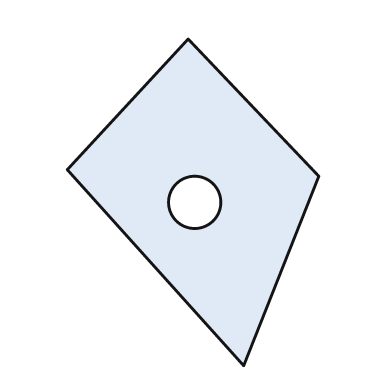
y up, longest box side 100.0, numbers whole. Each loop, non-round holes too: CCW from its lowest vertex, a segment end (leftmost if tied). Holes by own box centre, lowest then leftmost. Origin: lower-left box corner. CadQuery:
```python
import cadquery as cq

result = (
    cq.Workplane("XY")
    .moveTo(54.0, 0.0)
    .lineTo(77.0, 58.0)
    .lineTo(37.0, 100.0)
    .lineTo(0.0, 60.0)
    .close()
    .moveTo(39.0, 50.0)
    .circle(8.0)
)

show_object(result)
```